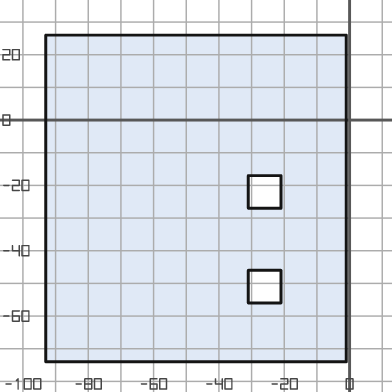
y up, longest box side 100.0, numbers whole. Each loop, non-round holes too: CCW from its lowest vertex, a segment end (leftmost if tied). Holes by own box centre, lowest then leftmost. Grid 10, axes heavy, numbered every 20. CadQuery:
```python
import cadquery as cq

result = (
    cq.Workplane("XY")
    .moveTo(-93.0, -74.0)
    .lineTo(-1.0, -74.0)
    .lineTo(-1.0, 26.0)
    .lineTo(-93.0, 26.0)
    .close()
    .moveTo(-31.0, -56.0)
    .lineTo(-21.0, -56.0)
    .lineTo(-21.0, -46.0)
    .lineTo(-31.0, -46.0)
    .close()
    .moveTo(-31.0, -27.0)
    .lineTo(-21.0, -27.0)
    .lineTo(-21.0, -17.0)
    .lineTo(-31.0, -17.0)
    .close()
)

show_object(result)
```